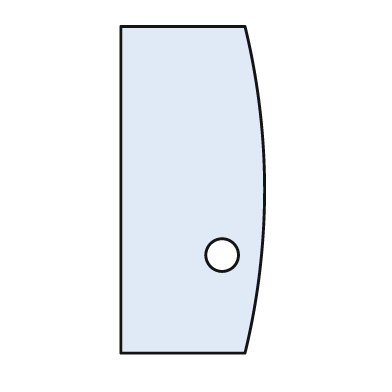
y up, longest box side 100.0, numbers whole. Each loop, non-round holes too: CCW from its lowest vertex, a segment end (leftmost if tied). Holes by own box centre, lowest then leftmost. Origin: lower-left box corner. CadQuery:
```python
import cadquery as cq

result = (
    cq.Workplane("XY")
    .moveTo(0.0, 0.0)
    .lineTo(38.0, 0.0)
    .threePointArc((44.0, 50.0), (38.0, 100.0))
    .lineTo(0.0, 100.0)
    .close()
    .moveTo(31.0, 30.0)
    .circle(5.0)
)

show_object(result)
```